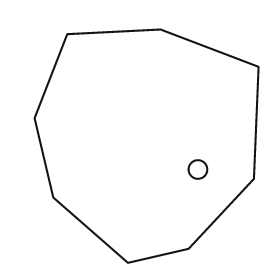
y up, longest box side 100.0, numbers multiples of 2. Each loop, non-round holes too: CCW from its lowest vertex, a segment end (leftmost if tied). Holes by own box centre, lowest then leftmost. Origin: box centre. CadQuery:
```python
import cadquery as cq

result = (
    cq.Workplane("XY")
    .moveTo(-8.0, -50.0)
    .lineTo(18.0, -44.0)
    .lineTo(46.0, -14.0)
    .lineTo(48.0, 34.0)
    .lineTo(6.0, 50.0)
    .lineTo(-34.0, 48.0)
    .lineTo(-48.0, 12.0)
    .lineTo(-40.0, -22.0)
    .close()
    .moveTo(22.0, -10.0)
    .circle(4.0)
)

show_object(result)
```